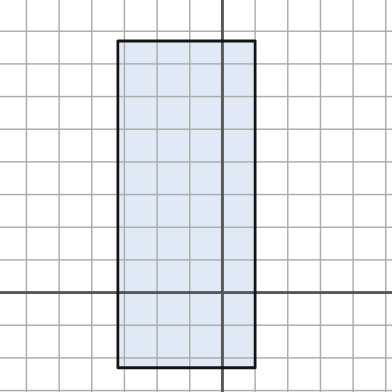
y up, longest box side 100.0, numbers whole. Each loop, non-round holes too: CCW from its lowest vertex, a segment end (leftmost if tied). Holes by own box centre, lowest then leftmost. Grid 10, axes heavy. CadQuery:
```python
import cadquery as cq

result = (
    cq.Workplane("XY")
    .moveTo(-32.0, -23.0)
    .lineTo(10.0, -23.0)
    .lineTo(10.0, 77.0)
    .lineTo(-32.0, 77.0)
    .close()
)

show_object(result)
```